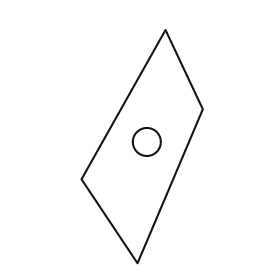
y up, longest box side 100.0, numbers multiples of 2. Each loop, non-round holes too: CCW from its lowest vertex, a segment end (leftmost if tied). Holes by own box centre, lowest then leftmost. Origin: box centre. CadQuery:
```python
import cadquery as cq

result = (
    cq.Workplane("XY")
    .moveTo(-2.0, -50.0)
    .lineTo(26.0, 16.0)
    .lineTo(10.0, 50.0)
    .lineTo(-26.0, -14.0)
    .close()
    .moveTo(2.0, 2.0)
    .circle(6.0)
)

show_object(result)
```